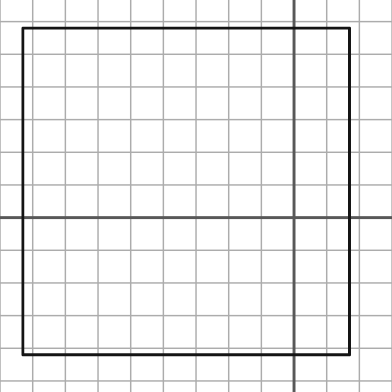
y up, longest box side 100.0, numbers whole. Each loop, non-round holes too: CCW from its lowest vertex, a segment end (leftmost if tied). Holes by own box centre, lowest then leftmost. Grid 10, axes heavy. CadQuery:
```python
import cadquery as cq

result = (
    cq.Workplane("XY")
    .moveTo(-83.0, -42.0)
    .lineTo(17.0, -42.0)
    .lineTo(17.0, 58.0)
    .lineTo(-83.0, 58.0)
    .close()
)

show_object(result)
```